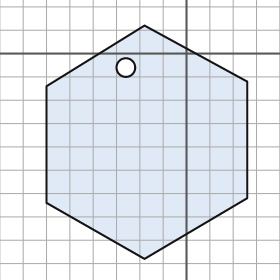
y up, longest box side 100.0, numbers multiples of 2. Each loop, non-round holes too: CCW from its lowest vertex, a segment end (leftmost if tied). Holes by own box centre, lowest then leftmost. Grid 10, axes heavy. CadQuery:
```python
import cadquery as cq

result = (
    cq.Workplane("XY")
    .moveTo(-18.0, -88.0)
    .lineTo(26.0, -62.0)
    .lineTo(26.0, -12.0)
    .lineTo(-18.0, 12.0)
    .lineTo(-60.0, -14.0)
    .lineTo(-60.0, -64.0)
    .close()
    .moveTo(-26.0, -6.0)
    .circle(4.0)
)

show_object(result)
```